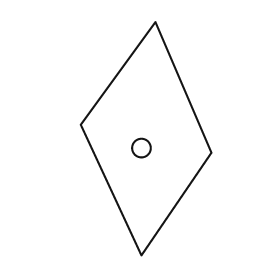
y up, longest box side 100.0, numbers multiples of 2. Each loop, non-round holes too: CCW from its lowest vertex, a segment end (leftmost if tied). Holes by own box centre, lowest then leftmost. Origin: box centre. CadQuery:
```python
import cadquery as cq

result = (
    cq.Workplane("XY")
    .moveTo(-2.0, -50.0)
    .lineTo(28.0, -6.0)
    .lineTo(4.0, 50.0)
    .lineTo(-28.0, 6.0)
    .close()
    .moveTo(-2.0, -4.0)
    .circle(4.0)
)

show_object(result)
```